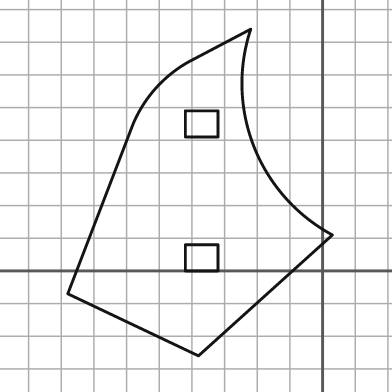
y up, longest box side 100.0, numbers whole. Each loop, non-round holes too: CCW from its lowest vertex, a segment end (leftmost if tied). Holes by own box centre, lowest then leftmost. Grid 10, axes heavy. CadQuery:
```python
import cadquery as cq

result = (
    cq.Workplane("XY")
    .moveTo(-38.0, -26.0)
    .lineTo(3.0, 11.0)
    .threePointArc((-21.0, 38.0), (-22.0, 74.0))
    .lineTo(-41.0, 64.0)
    .threePointArc((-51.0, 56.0), (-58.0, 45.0))
    .lineTo(-78.0, -7.0)
    .close()
    .moveTo(-42.0, 0.0)
    .lineTo(-32.0, 0.0)
    .lineTo(-32.0, 8.0)
    .lineTo(-42.0, 8.0)
    .close()
    .moveTo(-42.0, 41.0)
    .lineTo(-32.0, 41.0)
    .lineTo(-32.0, 49.0)
    .lineTo(-42.0, 49.0)
    .close()
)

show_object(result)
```